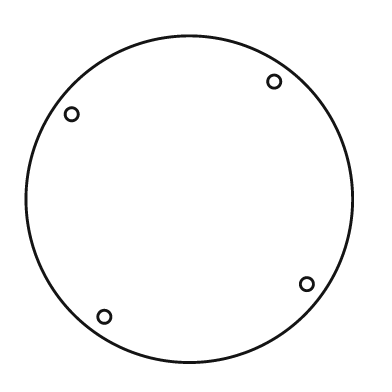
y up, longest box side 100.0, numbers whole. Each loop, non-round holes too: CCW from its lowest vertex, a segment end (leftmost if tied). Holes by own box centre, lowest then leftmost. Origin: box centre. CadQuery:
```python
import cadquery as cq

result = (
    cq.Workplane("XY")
    .moveTo(0.0, 0.0)
    .circle(50.0)
    .moveTo(-26.0, -36.0)
    .circle(2.0)
    .moveTo(36.0, -26.0)
    .circle(2.0)
    .moveTo(-36.0, 26.0)
    .circle(2.0)
    .moveTo(26.0, 36.0)
    .circle(2.0)
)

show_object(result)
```